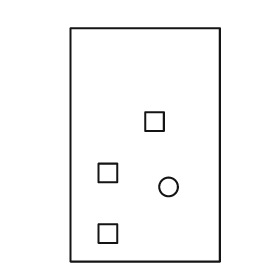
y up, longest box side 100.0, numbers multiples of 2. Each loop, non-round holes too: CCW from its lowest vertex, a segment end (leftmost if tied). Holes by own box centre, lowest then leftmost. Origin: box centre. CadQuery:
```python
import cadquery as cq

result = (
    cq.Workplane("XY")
    .moveTo(-32.0, -50.0)
    .lineTo(32.0, -50.0)
    .lineTo(32.0, 50.0)
    .lineTo(-32.0, 50.0)
    .close()
    .moveTo(-20.0, -42.0)
    .lineTo(-12.0, -42.0)
    .lineTo(-12.0, -34.0)
    .lineTo(-20.0, -34.0)
    .close()
    .moveTo(10.0, -18.0)
    .circle(4.0)
    .moveTo(-20.0, -16.0)
    .lineTo(-12.0, -16.0)
    .lineTo(-12.0, -8.0)
    .lineTo(-20.0, -8.0)
    .close()
    .moveTo(0.0, 6.0)
    .lineTo(8.0, 6.0)
    .lineTo(8.0, 14.0)
    .lineTo(0.0, 14.0)
    .close()
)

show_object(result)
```